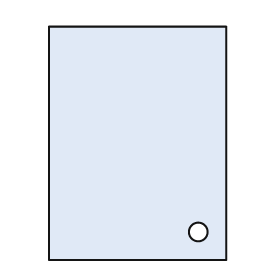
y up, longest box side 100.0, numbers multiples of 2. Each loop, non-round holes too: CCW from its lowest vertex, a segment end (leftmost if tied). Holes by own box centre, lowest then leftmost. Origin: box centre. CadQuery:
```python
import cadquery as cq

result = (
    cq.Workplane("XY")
    .moveTo(-38.0, -50.0)
    .lineTo(38.0, -50.0)
    .lineTo(38.0, 50.0)
    .lineTo(-38.0, 50.0)
    .close()
    .moveTo(26.0, -38.0)
    .circle(4.0)
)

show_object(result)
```